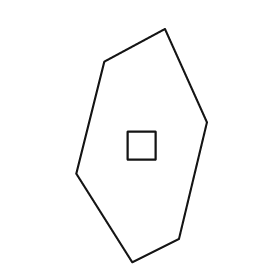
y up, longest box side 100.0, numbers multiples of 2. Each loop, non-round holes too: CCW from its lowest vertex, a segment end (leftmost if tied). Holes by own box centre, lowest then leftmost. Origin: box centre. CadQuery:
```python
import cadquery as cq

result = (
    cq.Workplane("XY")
    .moveTo(-4.0, -50.0)
    .lineTo(16.0, -40.0)
    .lineTo(28.0, 10.0)
    .lineTo(10.0, 50.0)
    .lineTo(-16.0, 36.0)
    .lineTo(-28.0, -12.0)
    .close()
    .moveTo(-6.0, -6.0)
    .lineTo(6.0, -6.0)
    .lineTo(6.0, 6.0)
    .lineTo(-6.0, 6.0)
    .close()
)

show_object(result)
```